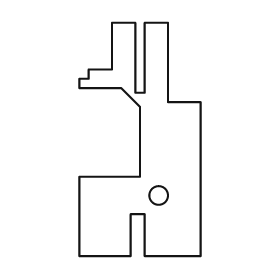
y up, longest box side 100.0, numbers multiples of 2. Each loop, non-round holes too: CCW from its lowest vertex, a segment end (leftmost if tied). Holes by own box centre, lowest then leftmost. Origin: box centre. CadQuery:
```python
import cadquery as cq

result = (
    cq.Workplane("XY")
    .moveTo(-26.0, -50.0)
    .lineTo(-4.0, -50.0)
    .lineTo(-4.0, -32.0)
    .lineTo(2.0, -32.0)
    .lineTo(2.0, -50.0)
    .lineTo(26.0, -50.0)
    .lineTo(26.0, 16.0)
    .lineTo(12.0, 16.0)
    .lineTo(12.0, 50.0)
    .lineTo(2.0, 50.0)
    .lineTo(2.0, 20.0)
    .lineTo(-2.0, 20.0)
    .lineTo(-2.0, 50.0)
    .lineTo(-12.0, 50.0)
    .lineTo(-12.0, 30.0)
    .lineTo(-22.0, 30.0)
    .lineTo(-22.0, 26.0)
    .lineTo(-26.0, 26.0)
    .lineTo(-26.0, 22.0)
    .lineTo(-8.0, 22.0)
    .lineTo(0.0, 14.0)
    .lineTo(0.0, -16.0)
    .lineTo(-26.0, -16.0)
    .close()
    .moveTo(8.0, -24.0)
    .circle(4.0)
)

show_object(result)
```